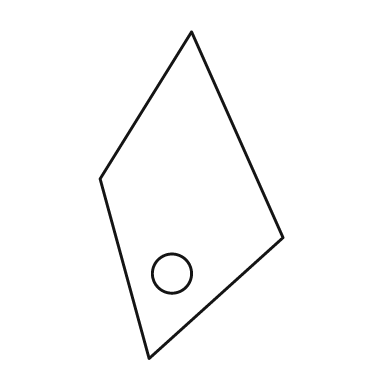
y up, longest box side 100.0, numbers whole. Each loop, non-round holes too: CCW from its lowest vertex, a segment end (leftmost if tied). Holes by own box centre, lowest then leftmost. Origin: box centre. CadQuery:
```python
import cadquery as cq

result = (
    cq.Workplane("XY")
    .moveTo(-13.0, -50.0)
    .lineTo(28.0, -13.0)
    .lineTo(0.0, 50.0)
    .lineTo(-28.0, 5.0)
    .close()
    .moveTo(-6.0, -24.0)
    .circle(6.0)
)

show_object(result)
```